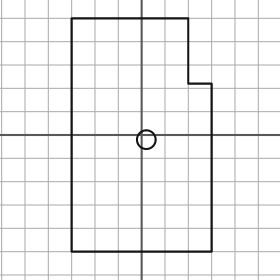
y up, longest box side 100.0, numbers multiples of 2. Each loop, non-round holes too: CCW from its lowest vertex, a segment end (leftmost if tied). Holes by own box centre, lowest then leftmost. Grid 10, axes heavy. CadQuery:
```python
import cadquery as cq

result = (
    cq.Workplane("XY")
    .moveTo(-30.0, -50.0)
    .lineTo(30.0, -50.0)
    .lineTo(30.0, 22.0)
    .lineTo(20.0, 22.0)
    .lineTo(20.0, 50.0)
    .lineTo(-30.0, 50.0)
    .close()
    .moveTo(2.0, -2.0)
    .circle(4.0)
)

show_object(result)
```